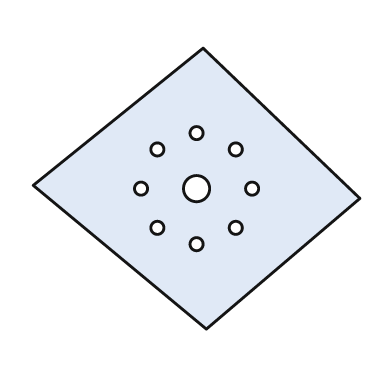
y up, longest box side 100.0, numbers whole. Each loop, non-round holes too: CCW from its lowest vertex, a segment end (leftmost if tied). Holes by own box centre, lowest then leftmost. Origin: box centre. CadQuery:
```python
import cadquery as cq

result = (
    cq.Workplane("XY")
    .moveTo(3.0, -43.0)
    .lineTo(50.0, -3.0)
    .lineTo(2.0, 43.0)
    .lineTo(-50.0, 1.0)
    .close()
    .moveTo(0.0, -17.0)
    .circle(2.0)
    .moveTo(-12.0, -12.0)
    .circle(2.0)
    .moveTo(12.0, -12.0)
    .circle(2.0)
    .moveTo(-17.0, 0.0)
    .circle(2.0)
    .moveTo(0.0, 0.0)
    .circle(4.0)
    .moveTo(17.0, 0.0)
    .circle(2.0)
    .moveTo(-12.0, 12.0)
    .circle(2.0)
    .moveTo(12.0, 12.0)
    .circle(2.0)
    .moveTo(0.0, 17.0)
    .circle(2.0)
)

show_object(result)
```